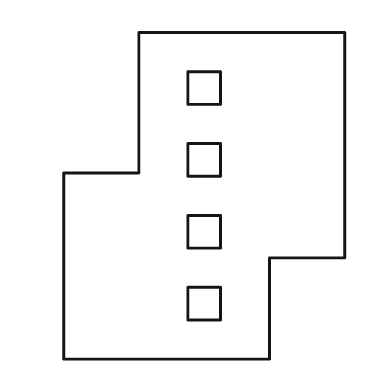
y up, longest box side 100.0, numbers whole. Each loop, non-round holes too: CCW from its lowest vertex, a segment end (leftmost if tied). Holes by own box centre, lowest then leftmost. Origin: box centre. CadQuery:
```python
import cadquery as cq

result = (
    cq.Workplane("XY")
    .moveTo(-43.0, -50.0)
    .lineTo(20.0, -50.0)
    .lineTo(20.0, -19.0)
    .lineTo(43.0, -19.0)
    .lineTo(43.0, 50.0)
    .lineTo(-20.0, 50.0)
    .lineTo(-20.0, 7.0)
    .lineTo(-43.0, 7.0)
    .close()
    .moveTo(-5.0, -38.0)
    .lineTo(5.0, -38.0)
    .lineTo(5.0, -28.0)
    .lineTo(-5.0, -28.0)
    .close()
    .moveTo(-5.0, -16.0)
    .lineTo(5.0, -16.0)
    .lineTo(5.0, -6.0)
    .lineTo(-5.0, -6.0)
    .close()
    .moveTo(-5.0, 6.0)
    .lineTo(5.0, 6.0)
    .lineTo(5.0, 16.0)
    .lineTo(-5.0, 16.0)
    .close()
    .moveTo(-5.0, 28.0)
    .lineTo(5.0, 28.0)
    .lineTo(5.0, 38.0)
    .lineTo(-5.0, 38.0)
    .close()
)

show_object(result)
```